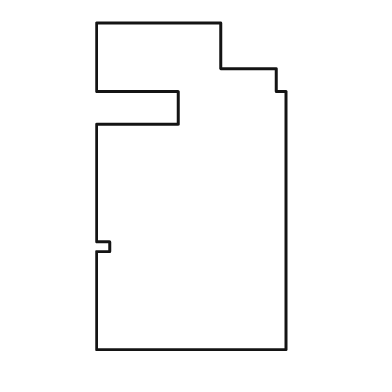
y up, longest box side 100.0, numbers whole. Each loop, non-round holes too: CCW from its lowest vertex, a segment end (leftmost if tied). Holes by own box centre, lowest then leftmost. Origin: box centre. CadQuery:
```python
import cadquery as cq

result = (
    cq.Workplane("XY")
    .moveTo(-29.0, -50.0)
    .lineTo(29.0, -50.0)
    .lineTo(29.0, 29.0)
    .lineTo(26.0, 29.0)
    .lineTo(26.0, 36.0)
    .lineTo(9.0, 36.0)
    .lineTo(9.0, 50.0)
    .lineTo(-29.0, 50.0)
    .lineTo(-29.0, 29.0)
    .lineTo(-4.0, 29.0)
    .lineTo(-4.0, 19.0)
    .lineTo(-29.0, 19.0)
    .lineTo(-29.0, -17.0)
    .lineTo(-25.0, -17.0)
    .lineTo(-25.0, -20.0)
    .lineTo(-29.0, -20.0)
    .close()
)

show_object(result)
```